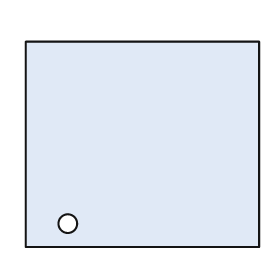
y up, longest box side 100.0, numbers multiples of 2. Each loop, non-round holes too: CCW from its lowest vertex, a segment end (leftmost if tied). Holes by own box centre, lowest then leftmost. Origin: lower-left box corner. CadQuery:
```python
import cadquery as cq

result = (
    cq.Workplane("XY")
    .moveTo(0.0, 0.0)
    .lineTo(100.0, 0.0)
    .lineTo(100.0, 88.0)
    .lineTo(0.0, 88.0)
    .close()
    .moveTo(18.0, 10.0)
    .circle(4.0)
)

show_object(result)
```